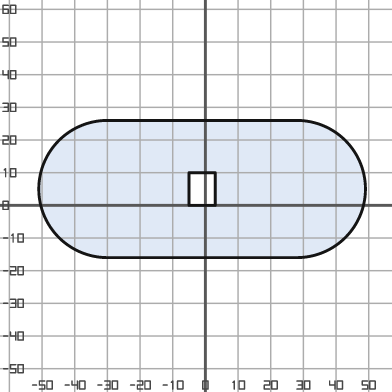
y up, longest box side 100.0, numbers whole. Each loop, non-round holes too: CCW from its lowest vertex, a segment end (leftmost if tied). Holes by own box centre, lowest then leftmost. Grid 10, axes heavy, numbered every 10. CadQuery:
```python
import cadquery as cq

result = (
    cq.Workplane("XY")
    .moveTo(-30.0, -16.0)
    .lineTo(28.0, -16.0)
    .threePointArc((49.0, 5.0), (28.0, 26.0))
    .lineTo(-30.0, 26.0)
    .threePointArc((-51.0, 5.0), (-30.0, -16.0))
    .close()
    .moveTo(-5.0, 0.0)
    .lineTo(3.0, 0.0)
    .lineTo(3.0, 10.0)
    .lineTo(-5.0, 10.0)
    .close()
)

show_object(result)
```